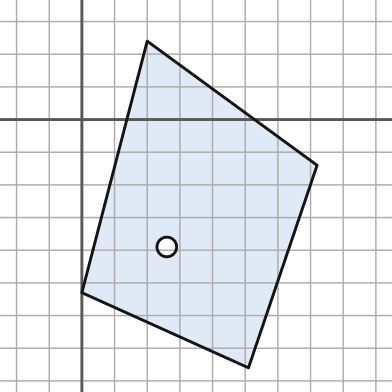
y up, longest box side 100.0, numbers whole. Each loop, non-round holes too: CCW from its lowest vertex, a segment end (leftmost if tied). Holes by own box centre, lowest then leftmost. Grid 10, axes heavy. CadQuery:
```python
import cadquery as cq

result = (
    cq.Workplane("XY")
    .moveTo(51.0, -76.0)
    .lineTo(72.0, -14.0)
    .lineTo(20.0, 24.0)
    .lineTo(0.0, -53.0)
    .close()
    .moveTo(26.0, -39.0)
    .circle(3.0)
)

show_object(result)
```